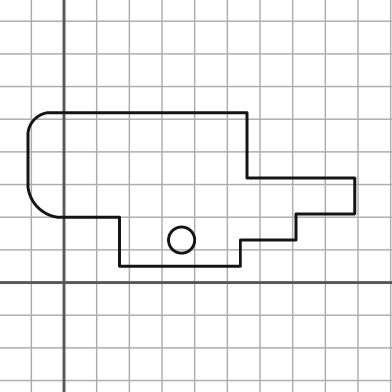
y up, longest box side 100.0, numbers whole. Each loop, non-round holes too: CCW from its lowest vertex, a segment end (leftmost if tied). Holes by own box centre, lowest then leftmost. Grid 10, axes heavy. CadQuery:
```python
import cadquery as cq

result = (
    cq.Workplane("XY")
    .moveTo(17.0, 5.0)
    .lineTo(54.0, 5.0)
    .lineTo(54.0, 13.0)
    .lineTo(71.0, 13.0)
    .lineTo(71.0, 21.0)
    .lineTo(89.0, 21.0)
    .lineTo(89.0, 32.0)
    .lineTo(56.0, 32.0)
    .lineTo(56.0, 52.0)
    .lineTo(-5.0, 52.0)
    .threePointArc((-9.0, 50.0), (-11.0, 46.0))
    .lineTo(-11.0, 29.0)
    .threePointArc((-8.0, 23.0), (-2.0, 20.0))
    .lineTo(17.0, 20.0)
    .close()
    .moveTo(36.0, 13.0)
    .circle(4.0)
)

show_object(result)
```